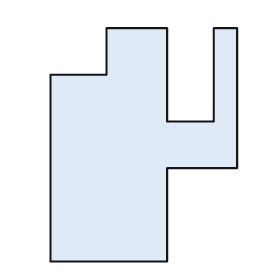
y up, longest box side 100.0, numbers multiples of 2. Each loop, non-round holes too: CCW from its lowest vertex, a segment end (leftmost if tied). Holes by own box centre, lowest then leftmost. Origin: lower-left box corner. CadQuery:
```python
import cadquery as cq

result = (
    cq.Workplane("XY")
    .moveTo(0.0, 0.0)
    .lineTo(50.0, 0.0)
    .lineTo(50.0, 40.0)
    .lineTo(80.0, 40.0)
    .lineTo(80.0, 100.0)
    .lineTo(70.0, 100.0)
    .lineTo(70.0, 60.0)
    .lineTo(50.0, 60.0)
    .lineTo(50.0, 100.0)
    .lineTo(24.0, 100.0)
    .lineTo(24.0, 80.0)
    .lineTo(0.0, 80.0)
    .close()
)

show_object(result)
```